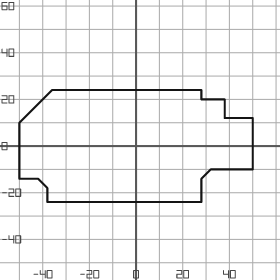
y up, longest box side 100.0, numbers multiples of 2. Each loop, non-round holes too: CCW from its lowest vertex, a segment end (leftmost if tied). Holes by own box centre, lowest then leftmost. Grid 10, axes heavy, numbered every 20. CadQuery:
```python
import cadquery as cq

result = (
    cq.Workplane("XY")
    .moveTo(-38.0, -24.0)
    .lineTo(28.0, -24.0)
    .lineTo(28.0, -14.0)
    .lineTo(32.0, -10.0)
    .lineTo(50.0, -10.0)
    .lineTo(50.0, 12.0)
    .lineTo(38.0, 12.0)
    .lineTo(38.0, 20.0)
    .lineTo(28.0, 20.0)
    .lineTo(28.0, 24.0)
    .lineTo(-36.0, 24.0)
    .lineTo(-50.0, 10.0)
    .lineTo(-50.0, -14.0)
    .lineTo(-42.0, -14.0)
    .lineTo(-38.0, -18.0)
    .close()
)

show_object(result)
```